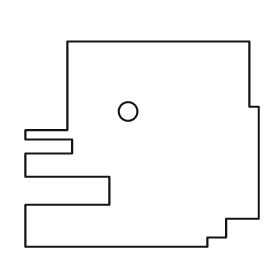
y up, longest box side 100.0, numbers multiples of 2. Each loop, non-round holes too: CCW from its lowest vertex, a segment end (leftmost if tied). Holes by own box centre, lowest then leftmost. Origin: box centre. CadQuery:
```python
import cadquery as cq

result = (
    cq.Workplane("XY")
    .moveTo(-50.0, -44.0)
    .lineTo(28.0, -44.0)
    .lineTo(28.0, -40.0)
    .lineTo(36.0, -40.0)
    .lineTo(36.0, -32.0)
    .lineTo(50.0, -32.0)
    .lineTo(50.0, 16.0)
    .lineTo(46.0, 16.0)
    .lineTo(46.0, 44.0)
    .lineTo(-32.0, 44.0)
    .lineTo(-32.0, 6.0)
    .lineTo(-50.0, 6.0)
    .lineTo(-50.0, 2.0)
    .lineTo(-30.0, 2.0)
    .lineTo(-30.0, -4.0)
    .lineTo(-50.0, -4.0)
    .lineTo(-50.0, -14.0)
    .lineTo(-14.0, -14.0)
    .lineTo(-14.0, -26.0)
    .lineTo(-50.0, -26.0)
    .close()
    .moveTo(-6.0, 14.0)
    .circle(4.0)
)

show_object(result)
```